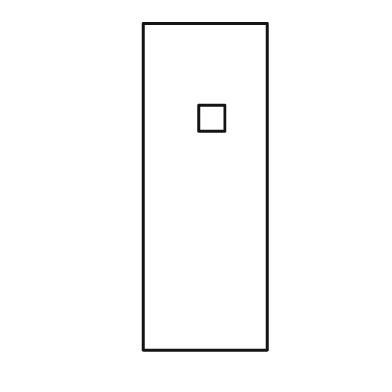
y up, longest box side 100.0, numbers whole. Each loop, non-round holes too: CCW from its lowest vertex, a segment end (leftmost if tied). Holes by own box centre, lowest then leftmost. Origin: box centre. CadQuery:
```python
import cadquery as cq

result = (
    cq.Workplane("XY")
    .moveTo(-19.0, -50.0)
    .lineTo(19.0, -50.0)
    .lineTo(19.0, 50.0)
    .lineTo(-19.0, 50.0)
    .close()
    .moveTo(-2.0, 17.0)
    .lineTo(6.0, 17.0)
    .lineTo(6.0, 25.0)
    .lineTo(-2.0, 25.0)
    .close()
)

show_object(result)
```